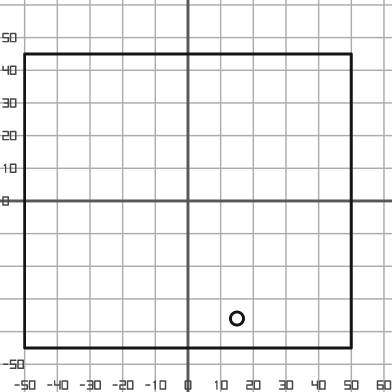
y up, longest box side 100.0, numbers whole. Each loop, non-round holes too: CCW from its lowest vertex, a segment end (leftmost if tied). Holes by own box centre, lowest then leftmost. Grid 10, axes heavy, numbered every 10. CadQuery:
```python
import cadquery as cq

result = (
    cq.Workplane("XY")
    .moveTo(-50.0, -45.0)
    .lineTo(50.0, -45.0)
    .lineTo(50.0, 45.0)
    .lineTo(-50.0, 45.0)
    .close()
    .moveTo(15.0, -36.0)
    .circle(2.0)
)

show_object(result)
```